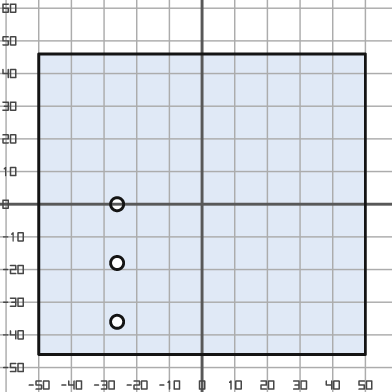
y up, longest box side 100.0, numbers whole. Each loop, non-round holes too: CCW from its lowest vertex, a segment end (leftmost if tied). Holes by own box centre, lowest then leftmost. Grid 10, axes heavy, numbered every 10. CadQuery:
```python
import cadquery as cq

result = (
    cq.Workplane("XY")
    .moveTo(-50.0, -46.0)
    .lineTo(50.0, -46.0)
    .lineTo(50.0, 46.0)
    .lineTo(-50.0, 46.0)
    .close()
    .moveTo(-26.0, -36.0)
    .circle(2.0)
    .moveTo(-26.0, -18.0)
    .circle(2.0)
    .moveTo(-26.0, 0.0)
    .circle(2.0)
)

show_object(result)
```